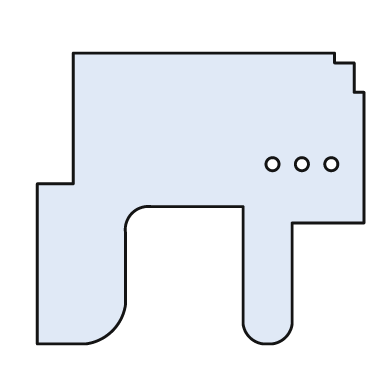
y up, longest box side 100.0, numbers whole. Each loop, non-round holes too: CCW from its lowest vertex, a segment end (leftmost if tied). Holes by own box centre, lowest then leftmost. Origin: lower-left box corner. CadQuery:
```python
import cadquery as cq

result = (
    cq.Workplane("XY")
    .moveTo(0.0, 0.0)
    .lineTo(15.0, 0.0)
    .threePointArc((23.0, 4.0), (27.0, 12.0))
    .lineTo(27.0, 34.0)
    .threePointArc((29.0, 40.0), (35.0, 42.0))
    .lineTo(63.0, 42.0)
    .lineTo(63.0, 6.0)
    .threePointArc((65.0, 2.0), (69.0, 0.0))
    .lineTo(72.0, 0.0)
    .threePointArc((76.0, 2.0), (78.0, 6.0))
    .lineTo(78.0, 37.0)
    .lineTo(100.0, 37.0)
    .lineTo(100.0, 77.0)
    .lineTo(97.0, 77.0)
    .lineTo(97.0, 86.0)
    .lineTo(91.0, 86.0)
    .lineTo(91.0, 89.0)
    .lineTo(11.0, 89.0)
    .lineTo(11.0, 49.0)
    .lineTo(0.0, 49.0)
    .close()
    .moveTo(72.0, 55.0)
    .circle(2.0)
    .moveTo(81.0, 55.0)
    .circle(2.0)
    .moveTo(90.0, 55.0)
    .circle(2.0)
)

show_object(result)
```